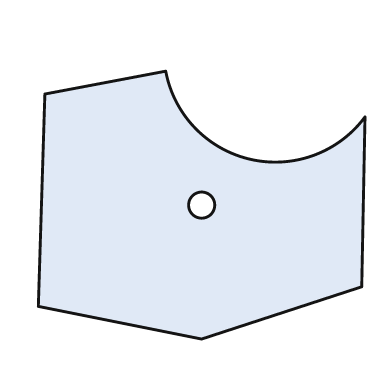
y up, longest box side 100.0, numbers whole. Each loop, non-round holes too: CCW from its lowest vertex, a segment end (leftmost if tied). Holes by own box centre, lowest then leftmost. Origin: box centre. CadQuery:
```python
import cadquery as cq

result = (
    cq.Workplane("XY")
    .moveTo(0.0, -41.0)
    .lineTo(49.0, -25.0)
    .lineTo(50.0, 27.0)
    .threePointArc((15.0, 14.0), (-11.0, 41.0))
    .lineTo(-48.0, 34.0)
    .lineTo(-50.0, -31.0)
    .close()
    .moveTo(0.0, 0.0)
    .circle(4.0)
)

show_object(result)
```